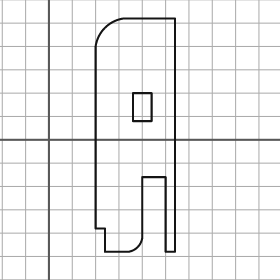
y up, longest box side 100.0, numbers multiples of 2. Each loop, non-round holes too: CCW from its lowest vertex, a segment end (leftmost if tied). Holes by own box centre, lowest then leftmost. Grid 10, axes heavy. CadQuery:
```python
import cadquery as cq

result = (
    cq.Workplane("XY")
    .moveTo(24.0, -48.0)
    .lineTo(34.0, -48.0)
    .threePointArc((38.0, -46.0), (40.0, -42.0))
    .lineTo(40.0, -16.0)
    .lineTo(50.0, -16.0)
    .lineTo(50.0, -48.0)
    .lineTo(54.0, -48.0)
    .lineTo(54.0, 52.0)
    .lineTo(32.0, 52.0)
    .threePointArc((24.0, 48.0), (20.0, 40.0))
    .lineTo(20.0, -38.0)
    .lineTo(24.0, -38.0)
    .close()
    .moveTo(36.0, 8.0)
    .lineTo(44.0, 8.0)
    .lineTo(44.0, 20.0)
    .lineTo(36.0, 20.0)
    .close()
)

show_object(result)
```